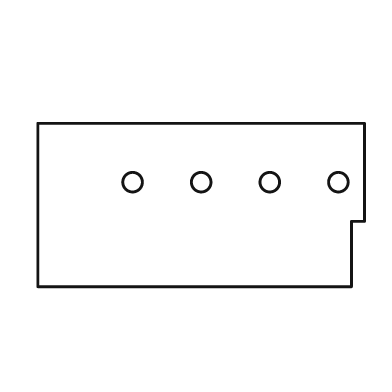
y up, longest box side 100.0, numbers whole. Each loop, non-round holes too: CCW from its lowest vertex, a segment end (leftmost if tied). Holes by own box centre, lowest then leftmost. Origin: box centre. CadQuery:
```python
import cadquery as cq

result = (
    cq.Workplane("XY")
    .moveTo(-50.0, -25.0)
    .lineTo(46.0, -25.0)
    .lineTo(46.0, -5.0)
    .lineTo(50.0, -5.0)
    .lineTo(50.0, 25.0)
    .lineTo(-50.0, 25.0)
    .close()
    .moveTo(-21.0, 7.0)
    .circle(3.0)
    .moveTo(0.0, 7.0)
    .circle(3.0)
    .moveTo(21.0, 7.0)
    .circle(3.0)
    .moveTo(42.0, 7.0)
    .circle(3.0)
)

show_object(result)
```